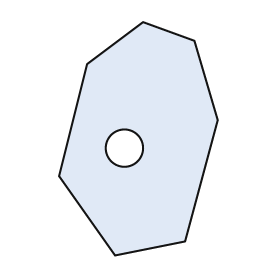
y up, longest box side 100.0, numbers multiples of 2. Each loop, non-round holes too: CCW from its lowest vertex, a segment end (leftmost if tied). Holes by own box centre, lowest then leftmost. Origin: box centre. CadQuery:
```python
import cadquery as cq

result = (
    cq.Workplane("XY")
    .moveTo(-10.0, -50.0)
    .lineTo(20.0, -44.0)
    .lineTo(34.0, 8.0)
    .lineTo(24.0, 42.0)
    .lineTo(2.0, 50.0)
    .lineTo(-22.0, 32.0)
    .lineTo(-34.0, -16.0)
    .close()
    .moveTo(-6.0, -4.0)
    .circle(8.0)
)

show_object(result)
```